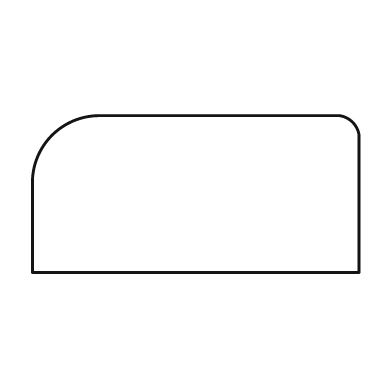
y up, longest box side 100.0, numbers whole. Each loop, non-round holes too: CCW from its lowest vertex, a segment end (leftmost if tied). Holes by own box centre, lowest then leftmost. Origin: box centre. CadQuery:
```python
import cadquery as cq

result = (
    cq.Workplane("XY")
    .moveTo(-50.0, -24.0)
    .lineTo(50.0, -24.0)
    .lineTo(50.0, 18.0)
    .threePointArc((48.0, 22.0), (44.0, 24.0))
    .lineTo(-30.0, 24.0)
    .threePointArc((-44.0, 18.0), (-50.0, 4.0))
    .close()
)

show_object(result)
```